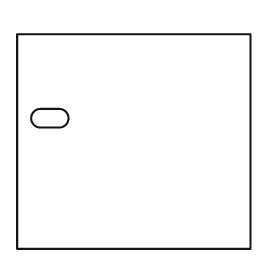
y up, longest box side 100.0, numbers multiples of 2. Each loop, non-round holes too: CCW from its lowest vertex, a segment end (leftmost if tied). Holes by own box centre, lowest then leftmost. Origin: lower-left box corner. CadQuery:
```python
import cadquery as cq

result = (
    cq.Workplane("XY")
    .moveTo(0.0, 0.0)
    .lineTo(100.0, 0.0)
    .lineTo(100.0, 92.0)
    .lineTo(0.0, 92.0)
    .close()
    .moveTo(10.0, 52.0)
    .lineTo(18.0, 52.0)
    .threePointArc((22.0, 56.0), (18.0, 60.0))
    .lineTo(10.0, 60.0)
    .threePointArc((6.0, 56.0), (10.0, 52.0))
    .close()
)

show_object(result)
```